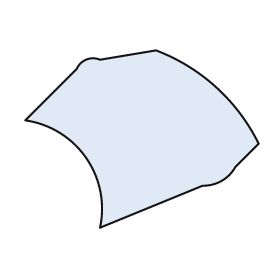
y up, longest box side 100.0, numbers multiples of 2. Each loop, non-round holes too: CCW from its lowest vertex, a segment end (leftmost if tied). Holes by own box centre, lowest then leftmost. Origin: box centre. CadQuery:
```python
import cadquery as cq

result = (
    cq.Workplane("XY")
    .moveTo(-18.0, -38.0)
    .lineTo(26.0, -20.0)
    .threePointArc((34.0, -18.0), (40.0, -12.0))
    .lineTo(50.0, -2.0)
    .threePointArc((32.0, 22.0), (6.0, 38.0))
    .lineTo(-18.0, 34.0)
    .threePointArc((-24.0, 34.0), (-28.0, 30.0))
    .lineTo(-50.0, 8.0)
    .threePointArc((-24.0, -8.0), (-18.0, -38.0))
    .close()
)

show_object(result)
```